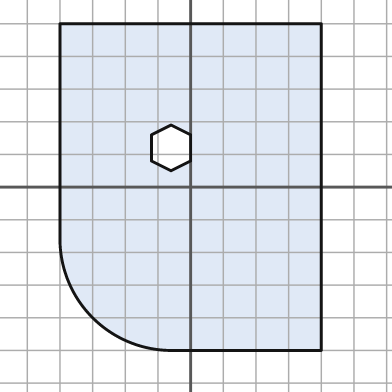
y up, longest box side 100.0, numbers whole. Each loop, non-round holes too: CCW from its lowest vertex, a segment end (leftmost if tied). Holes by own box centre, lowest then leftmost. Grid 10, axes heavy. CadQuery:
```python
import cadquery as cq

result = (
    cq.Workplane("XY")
    .moveTo(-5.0, -50.0)
    .lineTo(40.0, -50.0)
    .lineTo(40.0, 50.0)
    .lineTo(-40.0, 50.0)
    .lineTo(-40.0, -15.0)
    .threePointArc((-30.0, -40.0), (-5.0, -50.0))
    .close()
    .moveTo(-6.0, 5.0)
    .lineTo(0.0, 8.0)
    .lineTo(0.0, 16.0)
    .lineTo(-6.0, 19.0)
    .lineTo(-12.0, 16.0)
    .lineTo(-12.0, 8.0)
    .close()
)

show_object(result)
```